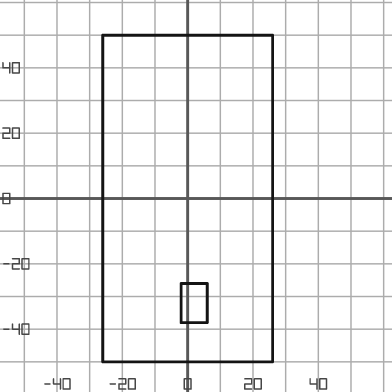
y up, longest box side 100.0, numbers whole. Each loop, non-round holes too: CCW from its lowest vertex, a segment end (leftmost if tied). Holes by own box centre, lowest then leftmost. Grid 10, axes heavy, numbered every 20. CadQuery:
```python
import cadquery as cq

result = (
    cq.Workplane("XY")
    .moveTo(-26.0, -50.0)
    .lineTo(26.0, -50.0)
    .lineTo(26.0, 50.0)
    .lineTo(-26.0, 50.0)
    .close()
    .moveTo(-2.0, -38.0)
    .lineTo(6.0, -38.0)
    .lineTo(6.0, -26.0)
    .lineTo(-2.0, -26.0)
    .close()
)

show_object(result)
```